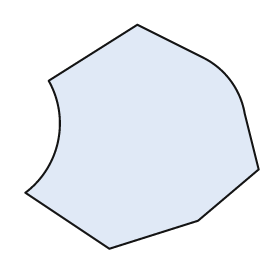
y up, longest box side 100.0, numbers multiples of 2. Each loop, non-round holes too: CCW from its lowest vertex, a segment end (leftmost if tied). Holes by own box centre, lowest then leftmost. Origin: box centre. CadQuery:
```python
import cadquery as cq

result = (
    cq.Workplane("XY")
    .moveTo(-14.0, -48.0)
    .lineTo(24.0, -36.0)
    .lineTo(50.0, -14.0)
    .lineTo(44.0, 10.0)
    .threePointArc((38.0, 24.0), (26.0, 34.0))
    .lineTo(-2.0, 48.0)
    .lineTo(-40.0, 24.0)
    .threePointArc((-36.0, -2.0), (-50.0, -24.0))
    .close()
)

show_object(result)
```